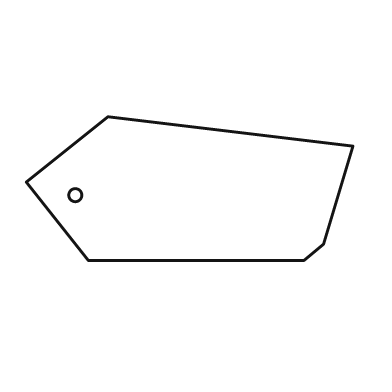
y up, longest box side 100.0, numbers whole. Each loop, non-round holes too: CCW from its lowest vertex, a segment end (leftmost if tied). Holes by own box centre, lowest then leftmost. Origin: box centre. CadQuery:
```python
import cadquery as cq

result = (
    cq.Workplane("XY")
    .moveTo(-31.0, -22.0)
    .lineTo(35.0, -22.0)
    .lineTo(41.0, -17.0)
    .lineTo(50.0, 13.0)
    .lineTo(-25.0, 22.0)
    .lineTo(-50.0, 2.0)
    .close()
    .moveTo(-35.0, -2.0)
    .circle(2.0)
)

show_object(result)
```